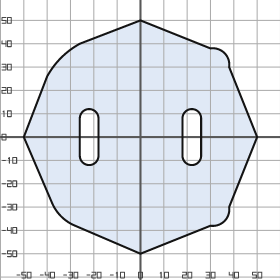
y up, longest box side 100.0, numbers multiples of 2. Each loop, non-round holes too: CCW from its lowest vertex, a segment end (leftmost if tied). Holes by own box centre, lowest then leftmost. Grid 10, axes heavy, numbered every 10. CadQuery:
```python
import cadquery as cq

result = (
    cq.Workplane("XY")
    .moveTo(0.0, -50.0)
    .lineTo(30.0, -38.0)
    .threePointArc((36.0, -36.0), (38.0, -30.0))
    .lineTo(50.0, 0.0)
    .lineTo(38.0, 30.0)
    .threePointArc((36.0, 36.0), (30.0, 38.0))
    .lineTo(0.0, 50.0)
    .lineTo(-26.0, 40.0)
    .threePointArc((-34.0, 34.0), (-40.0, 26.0))
    .lineTo(-50.0, 0.0)
    .lineTo(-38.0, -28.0)
    .threePointArc((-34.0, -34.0), (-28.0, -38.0))
    .close()
    .moveTo(-26.0, -8.0)
    .threePointArc((-22.0, -12.0), (-18.0, -8.0))
    .lineTo(-18.0, 8.0)
    .threePointArc((-22.0, 12.0), (-26.0, 8.0))
    .close()
    .moveTo(18.0, -8.0)
    .threePointArc((22.0, -12.0), (26.0, -8.0))
    .lineTo(26.0, 8.0)
    .threePointArc((22.0, 12.0), (18.0, 8.0))
    .close()
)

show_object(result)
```